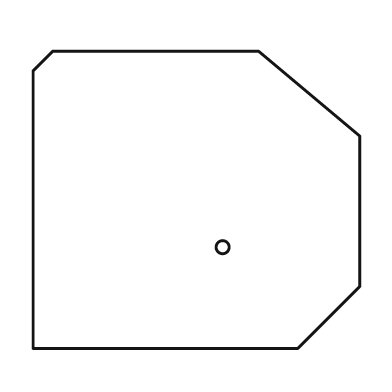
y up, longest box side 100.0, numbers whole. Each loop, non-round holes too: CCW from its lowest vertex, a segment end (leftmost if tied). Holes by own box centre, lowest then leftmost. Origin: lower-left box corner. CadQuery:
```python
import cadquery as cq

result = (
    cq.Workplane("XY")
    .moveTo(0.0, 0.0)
    .lineTo(81.0, 0.0)
    .lineTo(100.0, 19.0)
    .lineTo(100.0, 65.0)
    .lineTo(69.0, 91.0)
    .lineTo(6.0, 91.0)
    .lineTo(0.0, 85.0)
    .close()
    .moveTo(58.0, 31.0)
    .circle(2.0)
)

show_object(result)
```